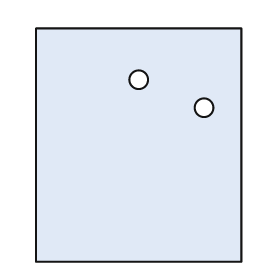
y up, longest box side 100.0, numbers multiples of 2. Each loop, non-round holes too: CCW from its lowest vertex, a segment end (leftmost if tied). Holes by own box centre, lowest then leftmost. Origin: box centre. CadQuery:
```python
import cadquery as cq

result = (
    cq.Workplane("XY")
    .moveTo(-44.0, -50.0)
    .lineTo(44.0, -50.0)
    .lineTo(44.0, 50.0)
    .lineTo(-44.0, 50.0)
    .close()
    .moveTo(28.0, 16.0)
    .circle(4.0)
    .moveTo(0.0, 28.0)
    .circle(4.0)
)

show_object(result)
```